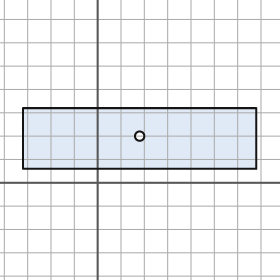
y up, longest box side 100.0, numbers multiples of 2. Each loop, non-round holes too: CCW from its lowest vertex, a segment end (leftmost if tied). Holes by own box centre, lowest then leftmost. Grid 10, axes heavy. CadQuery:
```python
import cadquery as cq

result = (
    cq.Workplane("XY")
    .moveTo(-32.0, 6.0)
    .lineTo(68.0, 6.0)
    .lineTo(68.0, 32.0)
    .lineTo(-32.0, 32.0)
    .close()
    .moveTo(18.0, 20.0)
    .circle(2.0)
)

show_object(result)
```